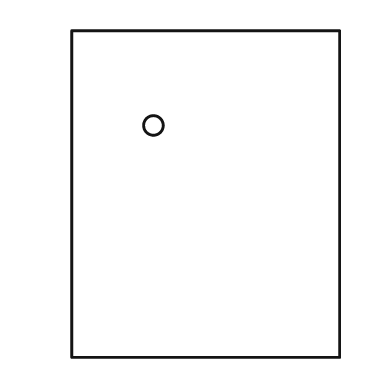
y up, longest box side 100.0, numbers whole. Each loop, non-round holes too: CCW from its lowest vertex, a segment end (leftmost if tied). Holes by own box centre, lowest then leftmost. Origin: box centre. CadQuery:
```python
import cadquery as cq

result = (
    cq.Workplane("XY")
    .moveTo(-41.0, -50.0)
    .lineTo(41.0, -50.0)
    .lineTo(41.0, 50.0)
    .lineTo(-41.0, 50.0)
    .close()
    .moveTo(-16.0, 21.0)
    .circle(3.0)
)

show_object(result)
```